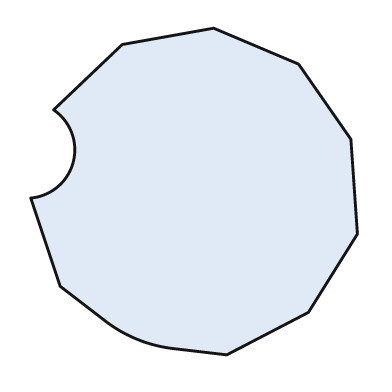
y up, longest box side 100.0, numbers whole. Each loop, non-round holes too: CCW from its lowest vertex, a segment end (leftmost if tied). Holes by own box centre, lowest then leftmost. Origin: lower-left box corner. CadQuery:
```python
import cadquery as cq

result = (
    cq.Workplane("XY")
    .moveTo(60.0, 0.0)
    .lineTo(85.0, 13.0)
    .lineTo(100.0, 37.0)
    .lineTo(98.0, 66.0)
    .lineTo(82.0, 89.0)
    .lineTo(56.0, 100.0)
    .lineTo(28.0, 95.0)
    .lineTo(7.0, 75.0)
    .threePointArc((13.0, 59.0), (0.0, 48.0))
    .lineTo(9.0, 21.0)
    .lineTo(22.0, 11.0)
    .threePointArc((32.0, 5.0), (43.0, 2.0))
    .close()
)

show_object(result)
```